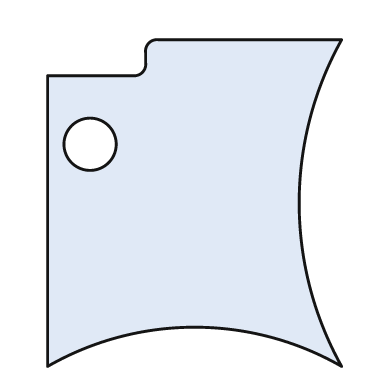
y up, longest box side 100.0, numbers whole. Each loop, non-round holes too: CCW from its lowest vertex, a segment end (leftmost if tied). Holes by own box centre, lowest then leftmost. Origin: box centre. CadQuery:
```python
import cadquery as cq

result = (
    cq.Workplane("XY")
    .moveTo(-45.0, -50.0)
    .threePointArc((0.0, -38.0), (45.0, -50.0))
    .threePointArc((32.0, 0.0), (45.0, 50.0))
    .lineTo(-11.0, 50.0)
    .threePointArc((-14.0, 49.0), (-15.0, 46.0))
    .lineTo(-15.0, 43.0)
    .threePointArc((-16.0, 40.0), (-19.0, 39.0))
    .lineTo(-45.0, 39.0)
    .close()
    .moveTo(-32.0, 18.0)
    .circle(8.0)
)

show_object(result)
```